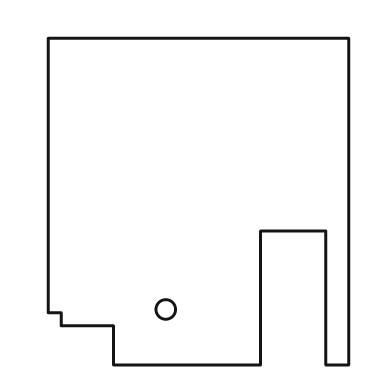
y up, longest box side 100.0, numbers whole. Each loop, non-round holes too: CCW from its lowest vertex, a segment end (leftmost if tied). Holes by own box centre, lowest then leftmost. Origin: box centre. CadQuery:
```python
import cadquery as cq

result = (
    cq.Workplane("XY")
    .moveTo(-26.0, -50.0)
    .lineTo(19.0, -50.0)
    .lineTo(19.0, -9.0)
    .lineTo(39.0, -9.0)
    .lineTo(39.0, -50.0)
    .lineTo(46.0, -50.0)
    .lineTo(46.0, 50.0)
    .lineTo(-46.0, 50.0)
    .lineTo(-46.0, -34.0)
    .lineTo(-42.0, -34.0)
    .lineTo(-42.0, -38.0)
    .lineTo(-26.0, -38.0)
    .close()
    .moveTo(-10.0, -33.0)
    .circle(3.0)
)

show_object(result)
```